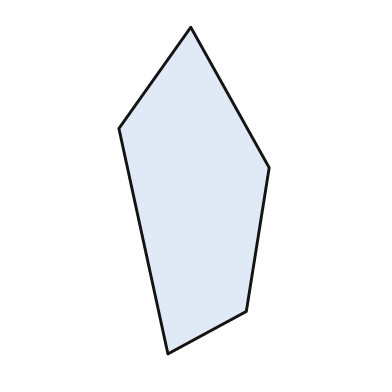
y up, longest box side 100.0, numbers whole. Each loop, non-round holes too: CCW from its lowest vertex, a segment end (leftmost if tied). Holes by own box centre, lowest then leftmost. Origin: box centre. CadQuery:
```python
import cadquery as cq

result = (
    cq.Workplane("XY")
    .moveTo(-8.0, -50.0)
    .lineTo(16.0, -37.0)
    .lineTo(23.0, 7.0)
    .lineTo(-1.0, 50.0)
    .lineTo(-23.0, 19.0)
    .close()
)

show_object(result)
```